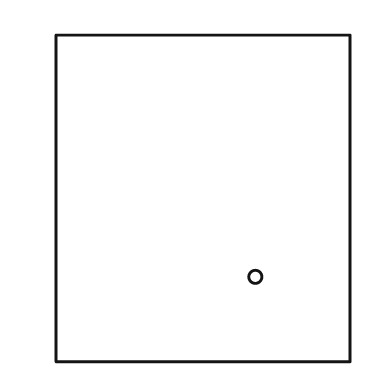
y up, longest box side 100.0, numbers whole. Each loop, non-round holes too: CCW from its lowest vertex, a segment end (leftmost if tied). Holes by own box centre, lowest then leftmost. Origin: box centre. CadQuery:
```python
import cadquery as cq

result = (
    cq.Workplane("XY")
    .moveTo(-45.0, -50.0)
    .lineTo(45.0, -50.0)
    .lineTo(45.0, 50.0)
    .lineTo(-45.0, 50.0)
    .close()
    .moveTo(16.0, -24.0)
    .circle(2.0)
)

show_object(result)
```